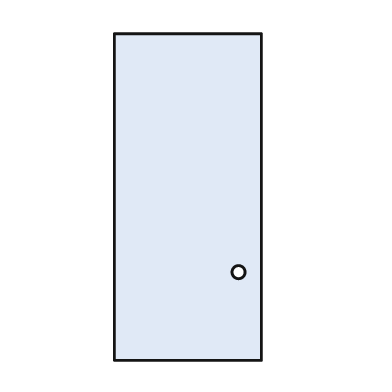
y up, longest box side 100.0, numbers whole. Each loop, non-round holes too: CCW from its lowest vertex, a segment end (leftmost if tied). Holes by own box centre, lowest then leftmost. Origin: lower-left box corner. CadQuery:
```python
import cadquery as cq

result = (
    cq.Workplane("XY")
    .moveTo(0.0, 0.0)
    .lineTo(45.0, 0.0)
    .lineTo(45.0, 100.0)
    .lineTo(0.0, 100.0)
    .close()
    .moveTo(38.0, 27.0)
    .circle(2.0)
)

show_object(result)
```